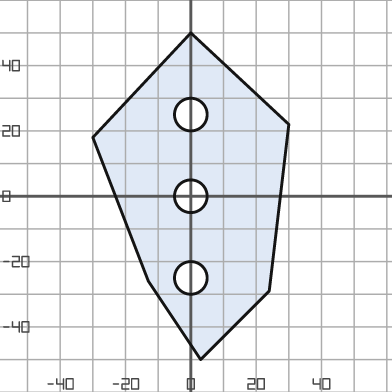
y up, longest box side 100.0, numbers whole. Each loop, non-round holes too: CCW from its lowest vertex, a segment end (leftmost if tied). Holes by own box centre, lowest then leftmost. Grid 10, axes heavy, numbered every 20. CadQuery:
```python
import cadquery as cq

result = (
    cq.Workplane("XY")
    .moveTo(3.0, -50.0)
    .lineTo(24.0, -29.0)
    .lineTo(30.0, 22.0)
    .lineTo(0.0, 50.0)
    .lineTo(-30.0, 18.0)
    .lineTo(-13.0, -26.0)
    .close()
    .moveTo(0.0, -25.0)
    .circle(5.0)
    .moveTo(0.0, 0.0)
    .circle(5.0)
    .moveTo(0.0, 25.0)
    .circle(5.0)
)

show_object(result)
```